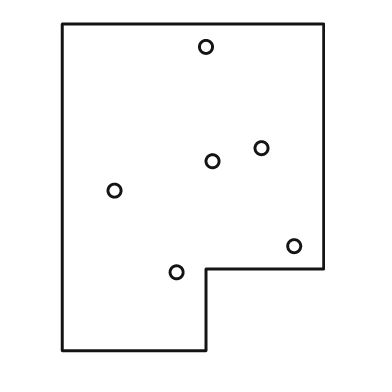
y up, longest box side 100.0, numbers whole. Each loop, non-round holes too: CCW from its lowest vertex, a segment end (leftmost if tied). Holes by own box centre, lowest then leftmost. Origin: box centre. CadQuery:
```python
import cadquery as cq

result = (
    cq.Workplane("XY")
    .moveTo(-40.0, -50.0)
    .lineTo(4.0, -50.0)
    .lineTo(4.0, -25.0)
    .lineTo(40.0, -25.0)
    .lineTo(40.0, 50.0)
    .lineTo(-40.0, 50.0)
    .close()
    .moveTo(-5.0, -26.0)
    .circle(2.0)
    .moveTo(31.0, -18.0)
    .circle(2.0)
    .moveTo(-24.0, -1.0)
    .circle(2.0)
    .moveTo(6.0, 8.0)
    .circle(2.0)
    .moveTo(21.0, 12.0)
    .circle(2.0)
    .moveTo(4.0, 43.0)
    .circle(2.0)
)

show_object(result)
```